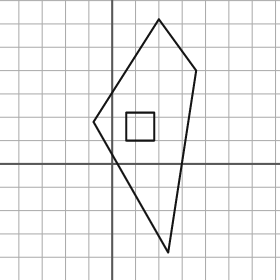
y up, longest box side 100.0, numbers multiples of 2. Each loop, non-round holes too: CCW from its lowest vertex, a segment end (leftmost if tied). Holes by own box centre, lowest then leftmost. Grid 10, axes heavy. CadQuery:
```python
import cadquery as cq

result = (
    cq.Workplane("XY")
    .moveTo(24.0, -38.0)
    .lineTo(36.0, 40.0)
    .lineTo(20.0, 62.0)
    .lineTo(-8.0, 18.0)
    .close()
    .moveTo(6.0, 10.0)
    .lineTo(18.0, 10.0)
    .lineTo(18.0, 22.0)
    .lineTo(6.0, 22.0)
    .close()
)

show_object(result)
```